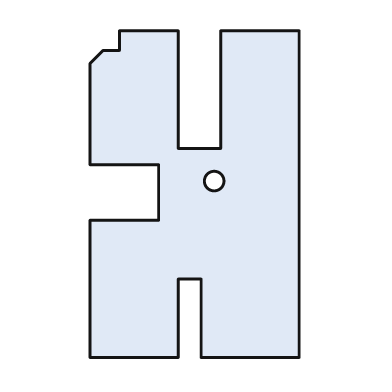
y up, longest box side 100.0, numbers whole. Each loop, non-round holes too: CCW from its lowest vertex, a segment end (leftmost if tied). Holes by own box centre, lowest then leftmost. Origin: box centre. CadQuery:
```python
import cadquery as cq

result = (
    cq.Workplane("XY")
    .moveTo(-32.0, -50.0)
    .lineTo(-5.0, -50.0)
    .lineTo(-5.0, -26.0)
    .lineTo(2.0, -26.0)
    .lineTo(2.0, -50.0)
    .lineTo(32.0, -50.0)
    .lineTo(32.0, 50.0)
    .lineTo(8.0, 50.0)
    .lineTo(8.0, 14.0)
    .lineTo(-5.0, 14.0)
    .lineTo(-5.0, 50.0)
    .lineTo(-23.0, 50.0)
    .lineTo(-23.0, 44.0)
    .lineTo(-28.0, 44.0)
    .lineTo(-32.0, 40.0)
    .lineTo(-32.0, 9.0)
    .lineTo(-11.0, 9.0)
    .lineTo(-11.0, -8.0)
    .lineTo(-32.0, -8.0)
    .close()
    .moveTo(6.0, 4.0)
    .circle(3.0)
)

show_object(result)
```